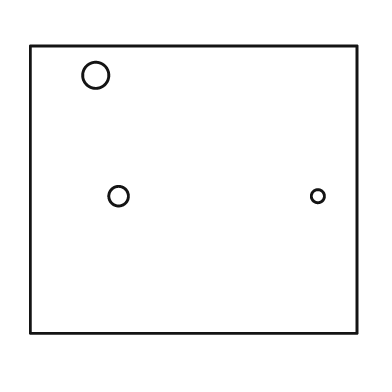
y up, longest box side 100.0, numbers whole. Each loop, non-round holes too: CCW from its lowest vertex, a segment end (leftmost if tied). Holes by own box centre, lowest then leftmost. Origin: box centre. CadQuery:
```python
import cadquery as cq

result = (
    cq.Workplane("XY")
    .moveTo(-50.0, -44.0)
    .lineTo(50.0, -44.0)
    .lineTo(50.0, 44.0)
    .lineTo(-50.0, 44.0)
    .close()
    .moveTo(-23.0, -2.0)
    .circle(3.0)
    .moveTo(38.0, -2.0)
    .circle(2.0)
    .moveTo(-30.0, 35.0)
    .circle(4.0)
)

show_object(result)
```